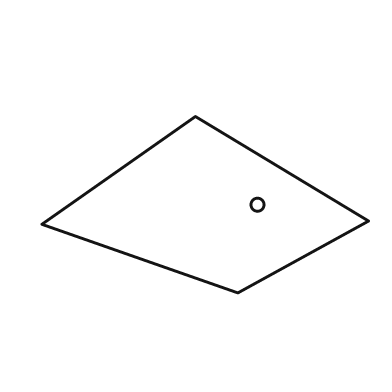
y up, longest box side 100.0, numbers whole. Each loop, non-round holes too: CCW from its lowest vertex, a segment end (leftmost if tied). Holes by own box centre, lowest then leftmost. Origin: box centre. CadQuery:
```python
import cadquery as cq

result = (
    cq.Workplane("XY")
    .moveTo(10.0, -27.0)
    .lineTo(50.0, -5.0)
    .lineTo(-3.0, 27.0)
    .lineTo(-50.0, -6.0)
    .close()
    .moveTo(16.0, 0.0)
    .circle(2.0)
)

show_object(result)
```